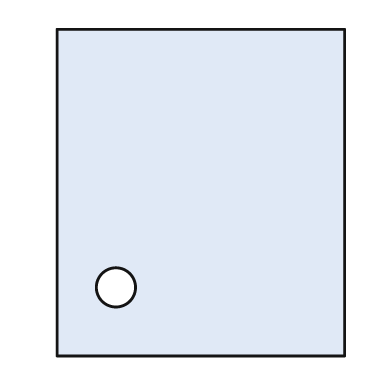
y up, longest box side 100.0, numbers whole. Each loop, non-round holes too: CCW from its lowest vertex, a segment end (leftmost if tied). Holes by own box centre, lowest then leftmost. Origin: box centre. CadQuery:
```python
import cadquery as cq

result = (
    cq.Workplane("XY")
    .moveTo(-44.0, -50.0)
    .lineTo(44.0, -50.0)
    .lineTo(44.0, 50.0)
    .lineTo(-44.0, 50.0)
    .close()
    .moveTo(-26.0, -29.0)
    .circle(6.0)
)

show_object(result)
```